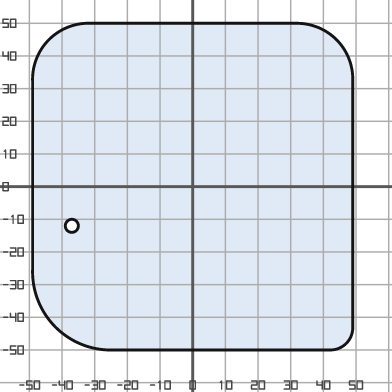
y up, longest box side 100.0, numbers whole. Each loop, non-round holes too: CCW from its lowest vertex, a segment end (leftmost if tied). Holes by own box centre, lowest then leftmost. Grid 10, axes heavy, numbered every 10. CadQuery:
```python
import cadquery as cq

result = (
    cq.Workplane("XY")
    .moveTo(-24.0, -50.0)
    .lineTo(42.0, -50.0)
    .threePointArc((47.0, -48.0), (49.0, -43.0))
    .lineTo(49.0, 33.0)
    .threePointArc((44.0, 45.0), (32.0, 50.0))
    .lineTo(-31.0, 50.0)
    .threePointArc((-44.0, 45.0), (-49.0, 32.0))
    .lineTo(-49.0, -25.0)
    .threePointArc((-42.0, -43.0), (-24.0, -50.0))
    .close()
    .moveTo(-37.0, -12.0)
    .circle(2.0)
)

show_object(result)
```